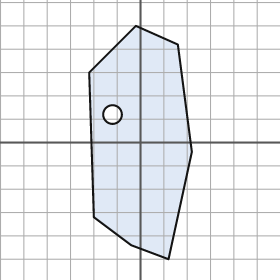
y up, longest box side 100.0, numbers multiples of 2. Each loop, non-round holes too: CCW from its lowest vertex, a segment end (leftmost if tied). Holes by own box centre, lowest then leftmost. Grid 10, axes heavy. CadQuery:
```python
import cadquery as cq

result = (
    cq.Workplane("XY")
    .moveTo(12.0, -50.0)
    .lineTo(22.0, -4.0)
    .lineTo(16.0, 42.0)
    .lineTo(-2.0, 50.0)
    .lineTo(-22.0, 30.0)
    .lineTo(-20.0, -32.0)
    .lineTo(-4.0, -44.0)
    .close()
    .moveTo(-12.0, 12.0)
    .circle(4.0)
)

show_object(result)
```